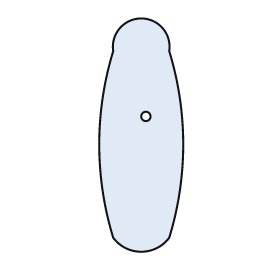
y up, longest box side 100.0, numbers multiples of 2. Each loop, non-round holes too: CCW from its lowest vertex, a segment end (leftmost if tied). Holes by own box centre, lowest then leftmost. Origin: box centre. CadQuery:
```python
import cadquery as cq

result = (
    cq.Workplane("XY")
    .moveTo(-12.0, -44.0)
    .threePointArc((0.0, -50.0), (12.0, -44.0))
    .threePointArc((18.0, -4.0), (12.0, 36.0))
    .threePointArc((0.0, 50.0), (-12.0, 36.0))
    .threePointArc((-18.0, -4.0), (-12.0, -44.0))
    .close()
    .moveTo(2.0, 8.0)
    .circle(2.0)
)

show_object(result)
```